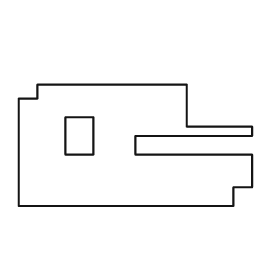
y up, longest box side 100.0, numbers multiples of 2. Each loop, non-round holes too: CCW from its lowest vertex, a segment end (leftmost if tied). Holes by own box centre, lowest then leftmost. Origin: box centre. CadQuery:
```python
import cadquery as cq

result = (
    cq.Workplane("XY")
    .moveTo(-50.0, -26.0)
    .lineTo(42.0, -26.0)
    .lineTo(42.0, -18.0)
    .lineTo(50.0, -18.0)
    .lineTo(50.0, -4.0)
    .lineTo(0.0, -4.0)
    .lineTo(0.0, 4.0)
    .lineTo(50.0, 4.0)
    .lineTo(50.0, 8.0)
    .lineTo(22.0, 8.0)
    .lineTo(22.0, 26.0)
    .lineTo(-42.0, 26.0)
    .lineTo(-42.0, 20.0)
    .lineTo(-50.0, 20.0)
    .close()
    .moveTo(-30.0, -4.0)
    .lineTo(-18.0, -4.0)
    .lineTo(-18.0, 12.0)
    .lineTo(-30.0, 12.0)
    .close()
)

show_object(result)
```